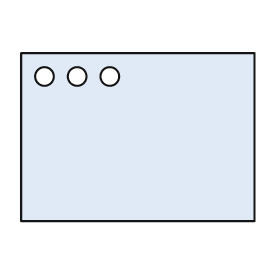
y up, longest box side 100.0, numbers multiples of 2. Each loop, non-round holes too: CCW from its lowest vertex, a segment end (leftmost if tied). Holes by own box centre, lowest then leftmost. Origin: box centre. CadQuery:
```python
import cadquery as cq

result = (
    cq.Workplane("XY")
    .moveTo(-50.0, -36.0)
    .lineTo(50.0, -36.0)
    .lineTo(50.0, 36.0)
    .lineTo(-50.0, 36.0)
    .close()
    .moveTo(-40.0, 26.0)
    .circle(4.0)
    .moveTo(-26.0, 26.0)
    .circle(4.0)
    .moveTo(-12.0, 26.0)
    .circle(4.0)
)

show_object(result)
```